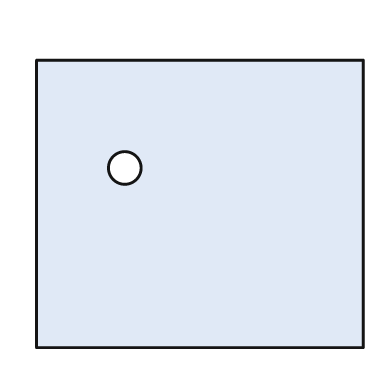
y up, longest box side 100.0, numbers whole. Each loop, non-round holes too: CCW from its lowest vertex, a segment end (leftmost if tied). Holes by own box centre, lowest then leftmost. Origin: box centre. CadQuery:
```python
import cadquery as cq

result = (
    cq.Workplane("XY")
    .moveTo(-50.0, -44.0)
    .lineTo(50.0, -44.0)
    .lineTo(50.0, 44.0)
    .lineTo(-50.0, 44.0)
    .close()
    .moveTo(-23.0, 11.0)
    .circle(5.0)
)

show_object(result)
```